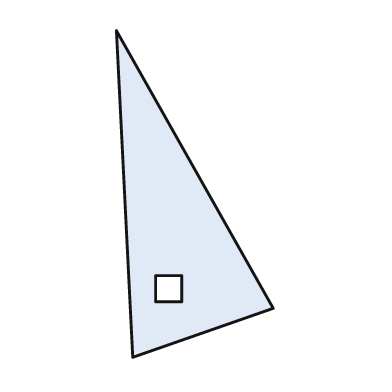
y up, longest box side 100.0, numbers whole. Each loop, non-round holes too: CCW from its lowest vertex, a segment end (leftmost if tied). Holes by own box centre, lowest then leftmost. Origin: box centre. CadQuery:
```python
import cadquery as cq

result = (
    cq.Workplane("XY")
    .moveTo(-19.0, -50.0)
    .lineTo(24.0, -35.0)
    .lineTo(-24.0, 50.0)
    .close()
    .moveTo(-12.0, -33.0)
    .lineTo(-4.0, -33.0)
    .lineTo(-4.0, -25.0)
    .lineTo(-12.0, -25.0)
    .close()
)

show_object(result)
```